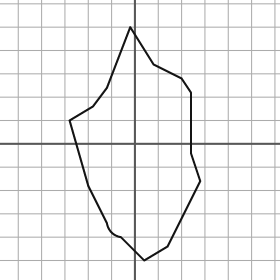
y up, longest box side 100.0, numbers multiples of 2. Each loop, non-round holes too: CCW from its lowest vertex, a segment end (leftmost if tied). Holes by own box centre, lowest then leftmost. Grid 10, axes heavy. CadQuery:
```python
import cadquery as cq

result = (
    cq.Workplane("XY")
    .moveTo(4.0, -50.0)
    .lineTo(14.0, -44.0)
    .lineTo(28.0, -16.0)
    .lineTo(24.0, -4.0)
    .lineTo(24.0, 22.0)
    .lineTo(20.0, 28.0)
    .lineTo(8.0, 34.0)
    .lineTo(-2.0, 50.0)
    .lineTo(-12.0, 24.0)
    .lineTo(-18.0, 16.0)
    .lineTo(-28.0, 10.0)
    .lineTo(-20.0, -18.0)
    .lineTo(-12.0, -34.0)
    .threePointArc((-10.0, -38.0), (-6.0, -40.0))
    .close()
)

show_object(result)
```